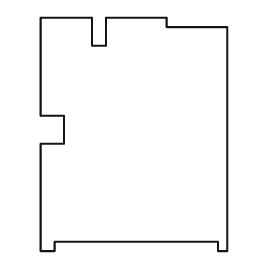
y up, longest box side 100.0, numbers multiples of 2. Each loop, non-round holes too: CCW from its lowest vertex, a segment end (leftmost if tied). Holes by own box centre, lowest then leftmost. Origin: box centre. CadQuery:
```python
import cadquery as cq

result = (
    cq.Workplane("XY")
    .moveTo(-40.0, -50.0)
    .lineTo(-34.0, -50.0)
    .lineTo(-34.0, -46.0)
    .lineTo(36.0, -46.0)
    .lineTo(36.0, -50.0)
    .lineTo(40.0, -50.0)
    .lineTo(40.0, 46.0)
    .lineTo(14.0, 46.0)
    .lineTo(14.0, 50.0)
    .lineTo(-12.0, 50.0)
    .lineTo(-12.0, 38.0)
    .lineTo(-18.0, 38.0)
    .lineTo(-18.0, 50.0)
    .lineTo(-40.0, 50.0)
    .lineTo(-40.0, 8.0)
    .lineTo(-30.0, 8.0)
    .lineTo(-30.0, -4.0)
    .lineTo(-40.0, -4.0)
    .close()
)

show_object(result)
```